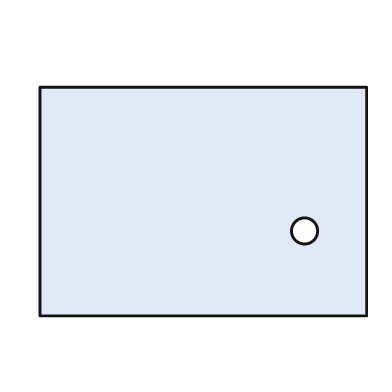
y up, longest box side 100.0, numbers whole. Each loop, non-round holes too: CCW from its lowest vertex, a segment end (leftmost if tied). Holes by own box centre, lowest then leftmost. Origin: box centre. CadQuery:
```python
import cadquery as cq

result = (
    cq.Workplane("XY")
    .moveTo(-50.0, -35.0)
    .lineTo(50.0, -35.0)
    .lineTo(50.0, 35.0)
    .lineTo(-50.0, 35.0)
    .close()
    .moveTo(31.0, -9.0)
    .circle(4.0)
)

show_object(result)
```